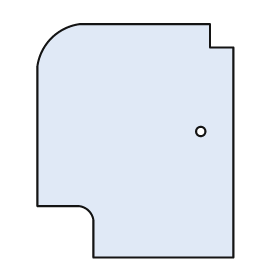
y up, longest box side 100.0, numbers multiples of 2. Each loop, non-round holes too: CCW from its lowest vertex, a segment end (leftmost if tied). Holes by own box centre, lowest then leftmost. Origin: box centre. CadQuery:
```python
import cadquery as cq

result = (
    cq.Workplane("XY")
    .moveTo(-18.0, -50.0)
    .lineTo(42.0, -50.0)
    .lineTo(42.0, 40.0)
    .lineTo(32.0, 40.0)
    .lineTo(32.0, 50.0)
    .lineTo(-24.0, 50.0)
    .threePointArc((-36.0, 44.0), (-42.0, 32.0))
    .lineTo(-42.0, -28.0)
    .lineTo(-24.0, -28.0)
    .threePointArc((-20.0, -30.0), (-18.0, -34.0))
    .close()
    .moveTo(28.0, 4.0)
    .circle(2.0)
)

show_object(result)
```